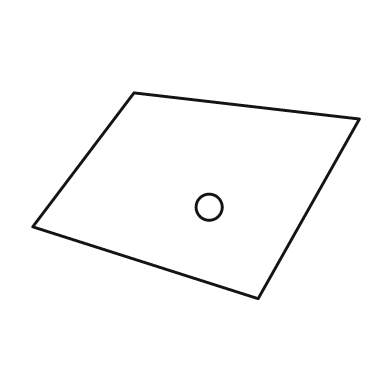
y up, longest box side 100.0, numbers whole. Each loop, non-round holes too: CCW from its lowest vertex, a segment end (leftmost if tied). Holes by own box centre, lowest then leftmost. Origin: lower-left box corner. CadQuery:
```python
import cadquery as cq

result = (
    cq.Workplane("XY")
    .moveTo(69.0, 0.0)
    .lineTo(100.0, 55.0)
    .lineTo(31.0, 63.0)
    .lineTo(0.0, 22.0)
    .close()
    .moveTo(54.0, 28.0)
    .circle(4.0)
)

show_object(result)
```